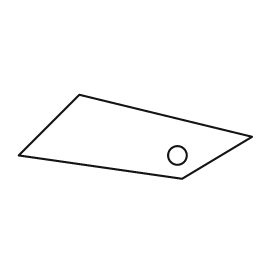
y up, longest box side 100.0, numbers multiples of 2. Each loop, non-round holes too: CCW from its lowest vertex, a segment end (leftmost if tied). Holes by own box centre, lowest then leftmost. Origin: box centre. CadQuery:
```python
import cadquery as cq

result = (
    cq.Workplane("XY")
    .moveTo(20.0, -18.0)
    .lineTo(50.0, 0.0)
    .lineTo(-24.0, 18.0)
    .lineTo(-50.0, -8.0)
    .close()
    .moveTo(18.0, -8.0)
    .circle(4.0)
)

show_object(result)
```